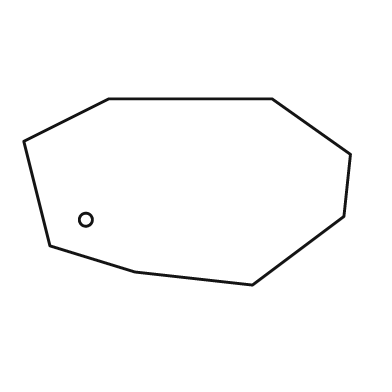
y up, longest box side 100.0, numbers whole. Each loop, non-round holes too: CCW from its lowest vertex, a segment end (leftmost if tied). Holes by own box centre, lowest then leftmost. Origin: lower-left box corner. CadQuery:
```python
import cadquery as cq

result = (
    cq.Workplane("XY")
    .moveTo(70.0, 0.0)
    .lineTo(98.0, 21.0)
    .lineTo(100.0, 40.0)
    .lineTo(76.0, 57.0)
    .lineTo(26.0, 57.0)
    .lineTo(0.0, 44.0)
    .lineTo(8.0, 12.0)
    .lineTo(34.0, 4.0)
    .close()
    .moveTo(19.0, 20.0)
    .circle(2.0)
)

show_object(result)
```